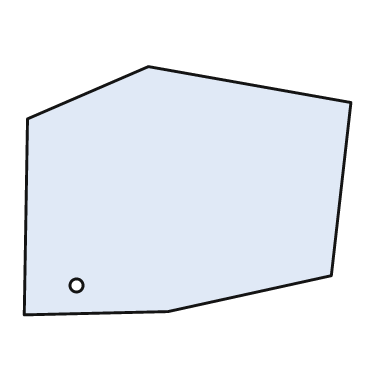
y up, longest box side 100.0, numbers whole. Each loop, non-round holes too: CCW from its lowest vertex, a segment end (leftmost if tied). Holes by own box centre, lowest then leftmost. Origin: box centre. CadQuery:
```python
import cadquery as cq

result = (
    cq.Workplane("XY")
    .moveTo(-50.0, -38.0)
    .lineTo(-6.0, -37.0)
    .lineTo(44.0, -26.0)
    .lineTo(50.0, 27.0)
    .lineTo(-12.0, 38.0)
    .lineTo(-49.0, 22.0)
    .close()
    .moveTo(-34.0, -29.0)
    .circle(2.0)
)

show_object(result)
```